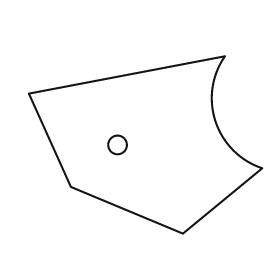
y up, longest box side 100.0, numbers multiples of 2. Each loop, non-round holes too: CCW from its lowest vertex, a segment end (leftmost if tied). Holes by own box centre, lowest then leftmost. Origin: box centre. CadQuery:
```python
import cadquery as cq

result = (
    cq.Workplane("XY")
    .moveTo(16.0, -38.0)
    .lineTo(50.0, -10.0)
    .threePointArc((30.0, 10.0), (34.0, 38.0))
    .lineTo(-50.0, 22.0)
    .lineTo(-32.0, -18.0)
    .close()
    .moveTo(-12.0, 0.0)
    .circle(4.0)
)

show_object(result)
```